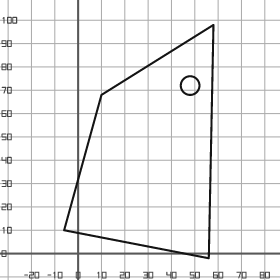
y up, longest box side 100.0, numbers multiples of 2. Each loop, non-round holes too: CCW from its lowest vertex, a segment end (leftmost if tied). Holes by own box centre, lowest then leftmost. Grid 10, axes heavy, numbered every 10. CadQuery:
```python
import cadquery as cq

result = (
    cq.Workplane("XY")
    .moveTo(56.0, -2.0)
    .lineTo(58.0, 98.0)
    .lineTo(10.0, 68.0)
    .lineTo(-6.0, 10.0)
    .close()
    .moveTo(48.0, 72.0)
    .circle(4.0)
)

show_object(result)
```